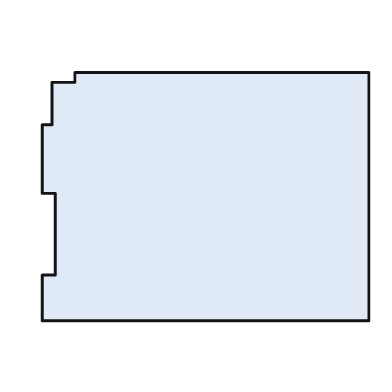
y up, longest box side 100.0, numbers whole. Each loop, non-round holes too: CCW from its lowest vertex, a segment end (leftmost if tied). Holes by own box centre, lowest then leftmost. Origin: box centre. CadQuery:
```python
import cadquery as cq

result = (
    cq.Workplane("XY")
    .moveTo(-50.0, -38.0)
    .lineTo(50.0, -38.0)
    .lineTo(50.0, 38.0)
    .lineTo(-40.0, 38.0)
    .lineTo(-40.0, 35.0)
    .lineTo(-47.0, 35.0)
    .lineTo(-47.0, 22.0)
    .lineTo(-50.0, 22.0)
    .lineTo(-50.0, 1.0)
    .lineTo(-46.0, 1.0)
    .lineTo(-46.0, -24.0)
    .lineTo(-50.0, -24.0)
    .close()
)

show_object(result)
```